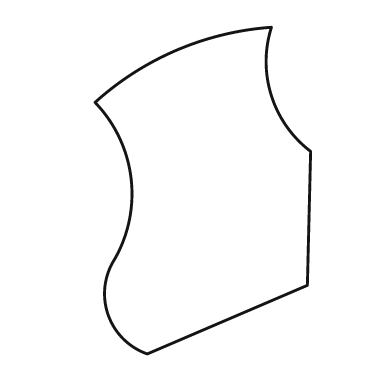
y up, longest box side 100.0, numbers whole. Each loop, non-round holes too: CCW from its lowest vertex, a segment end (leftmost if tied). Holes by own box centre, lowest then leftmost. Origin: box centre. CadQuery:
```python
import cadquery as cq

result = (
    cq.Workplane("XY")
    .moveTo(-17.0, -50.0)
    .lineTo(32.0, -29.0)
    .lineTo(33.0, 12.0)
    .threePointArc((21.0, 29.0), (21.0, 50.0))
    .threePointArc((-8.0, 43.0), (-33.0, 27.0))
    .threePointArc((-22.0, 4.0), (-27.0, -21.0))
    .threePointArc((-29.0, -38.0), (-17.0, -50.0))
    .close()
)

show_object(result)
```